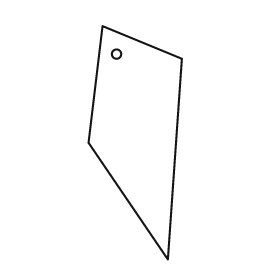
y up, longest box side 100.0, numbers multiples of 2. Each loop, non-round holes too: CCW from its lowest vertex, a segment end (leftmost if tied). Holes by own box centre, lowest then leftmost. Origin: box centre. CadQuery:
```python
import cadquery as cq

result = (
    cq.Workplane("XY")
    .moveTo(14.0, -50.0)
    .lineTo(20.0, 36.0)
    .lineTo(-14.0, 50.0)
    .lineTo(-20.0, 0.0)
    .close()
    .moveTo(-8.0, 38.0)
    .circle(2.0)
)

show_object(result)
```